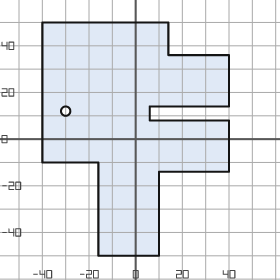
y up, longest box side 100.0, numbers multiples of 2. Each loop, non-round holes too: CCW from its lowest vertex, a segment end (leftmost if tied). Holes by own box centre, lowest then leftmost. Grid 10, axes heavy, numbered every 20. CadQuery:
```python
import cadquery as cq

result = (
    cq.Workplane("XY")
    .moveTo(-16.0, -50.0)
    .lineTo(10.0, -50.0)
    .lineTo(10.0, -14.0)
    .lineTo(40.0, -14.0)
    .lineTo(40.0, 8.0)
    .lineTo(6.0, 8.0)
    .lineTo(6.0, 14.0)
    .lineTo(40.0, 14.0)
    .lineTo(40.0, 36.0)
    .lineTo(14.0, 36.0)
    .lineTo(14.0, 50.0)
    .lineTo(-40.0, 50.0)
    .lineTo(-40.0, -10.0)
    .lineTo(-16.0, -10.0)
    .close()
    .moveTo(-30.0, 12.0)
    .circle(2.0)
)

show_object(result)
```